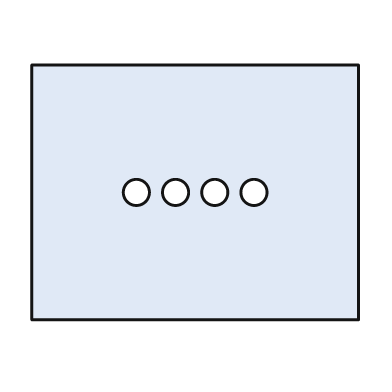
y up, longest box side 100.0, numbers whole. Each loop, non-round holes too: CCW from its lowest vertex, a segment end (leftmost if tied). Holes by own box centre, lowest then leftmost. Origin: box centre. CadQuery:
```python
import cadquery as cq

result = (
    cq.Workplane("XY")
    .moveTo(-50.0, -39.0)
    .lineTo(50.0, -39.0)
    .lineTo(50.0, 39.0)
    .lineTo(-50.0, 39.0)
    .close()
    .moveTo(-18.0, 0.0)
    .circle(4.0)
    .moveTo(-6.0, 0.0)
    .circle(4.0)
    .moveTo(6.0, 0.0)
    .circle(4.0)
    .moveTo(18.0, 0.0)
    .circle(4.0)
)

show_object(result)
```